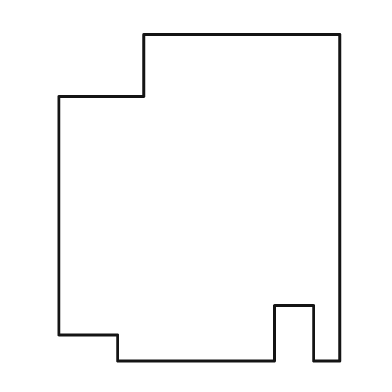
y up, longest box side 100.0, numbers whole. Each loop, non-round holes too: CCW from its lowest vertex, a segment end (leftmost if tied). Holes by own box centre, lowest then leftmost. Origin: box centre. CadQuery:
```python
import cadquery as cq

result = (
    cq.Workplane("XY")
    .moveTo(-25.0, -50.0)
    .lineTo(23.0, -50.0)
    .lineTo(23.0, -33.0)
    .lineTo(35.0, -33.0)
    .lineTo(35.0, -50.0)
    .lineTo(43.0, -50.0)
    .lineTo(43.0, 50.0)
    .lineTo(-17.0, 50.0)
    .lineTo(-17.0, 31.0)
    .lineTo(-43.0, 31.0)
    .lineTo(-43.0, -42.0)
    .lineTo(-25.0, -42.0)
    .close()
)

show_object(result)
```